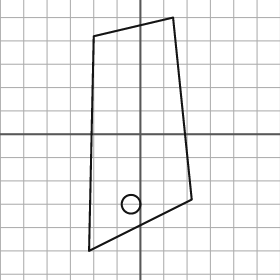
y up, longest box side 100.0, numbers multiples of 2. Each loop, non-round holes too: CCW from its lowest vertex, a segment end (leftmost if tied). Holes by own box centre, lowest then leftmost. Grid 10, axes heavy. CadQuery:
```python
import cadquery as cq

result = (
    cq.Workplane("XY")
    .moveTo(-22.0, -50.0)
    .lineTo(22.0, -28.0)
    .lineTo(14.0, 50.0)
    .lineTo(-20.0, 42.0)
    .close()
    .moveTo(-4.0, -30.0)
    .circle(4.0)
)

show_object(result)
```